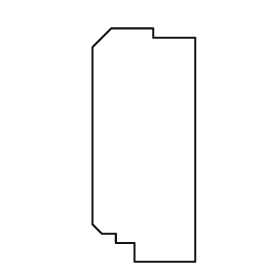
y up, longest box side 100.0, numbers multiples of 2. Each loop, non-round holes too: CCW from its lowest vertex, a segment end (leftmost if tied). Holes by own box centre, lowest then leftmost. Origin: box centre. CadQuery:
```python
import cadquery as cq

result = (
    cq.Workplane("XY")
    .moveTo(-4.0, -50.0)
    .lineTo(22.0, -50.0)
    .lineTo(22.0, 46.0)
    .lineTo(4.0, 46.0)
    .lineTo(4.0, 50.0)
    .lineTo(-14.0, 50.0)
    .lineTo(-22.0, 42.0)
    .lineTo(-22.0, -34.0)
    .lineTo(-18.0, -38.0)
    .lineTo(-12.0, -38.0)
    .lineTo(-12.0, -42.0)
    .lineTo(-4.0, -42.0)
    .close()
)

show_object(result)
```